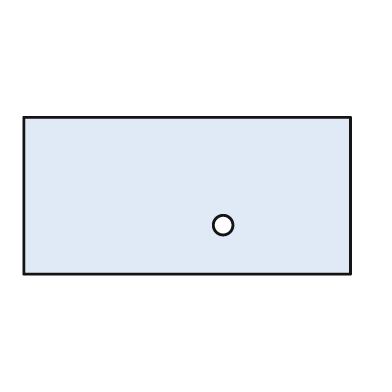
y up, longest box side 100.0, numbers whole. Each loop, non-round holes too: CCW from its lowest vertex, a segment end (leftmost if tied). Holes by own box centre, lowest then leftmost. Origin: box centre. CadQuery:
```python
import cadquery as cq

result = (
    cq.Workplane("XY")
    .moveTo(-50.0, -24.0)
    .lineTo(50.0, -24.0)
    .lineTo(50.0, 24.0)
    .lineTo(-50.0, 24.0)
    .close()
    .moveTo(11.0, -9.0)
    .circle(3.0)
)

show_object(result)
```